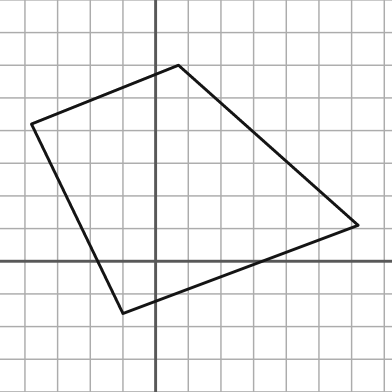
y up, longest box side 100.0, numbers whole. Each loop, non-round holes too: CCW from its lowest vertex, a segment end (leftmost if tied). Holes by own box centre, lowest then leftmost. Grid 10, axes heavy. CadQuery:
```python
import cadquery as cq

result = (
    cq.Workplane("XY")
    .moveTo(-10.0, -16.0)
    .lineTo(62.0, 11.0)
    .lineTo(7.0, 60.0)
    .lineTo(-38.0, 42.0)
    .close()
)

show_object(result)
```